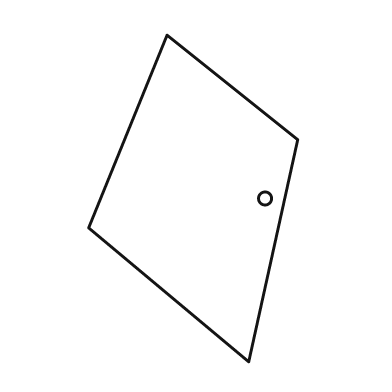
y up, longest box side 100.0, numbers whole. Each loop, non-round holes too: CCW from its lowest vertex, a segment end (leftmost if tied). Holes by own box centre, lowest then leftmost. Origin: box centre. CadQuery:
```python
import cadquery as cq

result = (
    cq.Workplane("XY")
    .moveTo(17.0, -50.0)
    .lineTo(32.0, 18.0)
    .lineTo(-8.0, 50.0)
    .lineTo(-32.0, -9.0)
    .close()
    .moveTo(22.0, 0.0)
    .circle(2.0)
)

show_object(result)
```